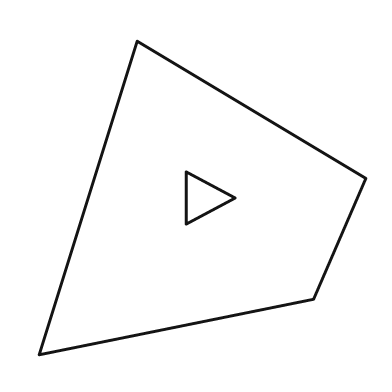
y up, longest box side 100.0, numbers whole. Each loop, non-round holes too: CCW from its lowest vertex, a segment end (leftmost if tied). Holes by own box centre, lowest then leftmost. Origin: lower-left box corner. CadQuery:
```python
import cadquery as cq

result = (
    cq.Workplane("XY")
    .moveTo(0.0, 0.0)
    .lineTo(84.0, 17.0)
    .lineTo(100.0, 54.0)
    .lineTo(30.0, 96.0)
    .close()
    .moveTo(45.0, 40.0)
    .lineTo(60.0, 48.0)
    .lineTo(45.0, 56.0)
    .close()
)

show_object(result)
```